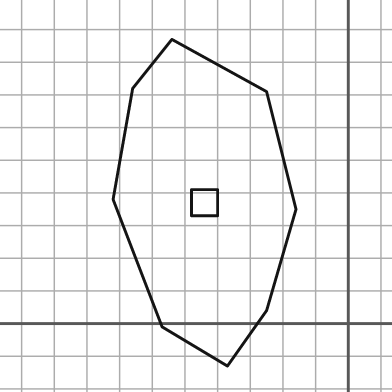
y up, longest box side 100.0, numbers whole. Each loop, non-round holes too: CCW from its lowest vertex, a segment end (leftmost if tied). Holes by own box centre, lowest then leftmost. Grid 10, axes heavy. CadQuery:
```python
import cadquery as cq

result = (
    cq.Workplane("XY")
    .moveTo(-37.0, -13.0)
    .lineTo(-25.0, 4.0)
    .lineTo(-16.0, 35.0)
    .lineTo(-25.0, 71.0)
    .lineTo(-54.0, 87.0)
    .lineTo(-66.0, 72.0)
    .lineTo(-72.0, 38.0)
    .lineTo(-57.0, -1.0)
    .close()
    .moveTo(-48.0, 33.0)
    .lineTo(-40.0, 33.0)
    .lineTo(-40.0, 41.0)
    .lineTo(-48.0, 41.0)
    .close()
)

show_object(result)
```